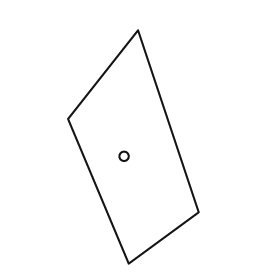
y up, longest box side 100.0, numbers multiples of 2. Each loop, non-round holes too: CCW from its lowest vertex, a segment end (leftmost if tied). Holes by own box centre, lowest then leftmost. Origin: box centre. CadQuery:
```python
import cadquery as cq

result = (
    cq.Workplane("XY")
    .moveTo(-2.0, -50.0)
    .lineTo(28.0, -28.0)
    .lineTo(2.0, 50.0)
    .lineTo(-28.0, 12.0)
    .close()
    .moveTo(-4.0, -4.0)
    .circle(2.0)
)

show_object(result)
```